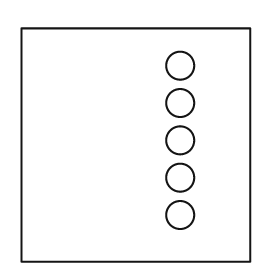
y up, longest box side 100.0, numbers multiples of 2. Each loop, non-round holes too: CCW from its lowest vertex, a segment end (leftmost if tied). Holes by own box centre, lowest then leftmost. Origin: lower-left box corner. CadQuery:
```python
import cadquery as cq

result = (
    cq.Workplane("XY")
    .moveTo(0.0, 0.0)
    .lineTo(98.0, 0.0)
    .lineTo(98.0, 100.0)
    .lineTo(0.0, 100.0)
    .close()
    .moveTo(68.0, 20.0)
    .circle(6.0)
    .moveTo(68.0, 36.0)
    .circle(6.0)
    .moveTo(68.0, 52.0)
    .circle(6.0)
    .moveTo(68.0, 68.0)
    .circle(6.0)
    .moveTo(68.0, 84.0)
    .circle(6.0)
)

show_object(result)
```